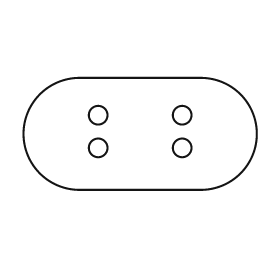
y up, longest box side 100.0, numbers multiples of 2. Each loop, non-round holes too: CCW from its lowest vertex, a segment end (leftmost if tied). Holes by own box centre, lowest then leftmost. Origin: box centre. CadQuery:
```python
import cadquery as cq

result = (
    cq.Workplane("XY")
    .moveTo(-26.0, -24.0)
    .lineTo(26.0, -24.0)
    .threePointArc((50.0, 0.0), (26.0, 24.0))
    .lineTo(-26.0, 24.0)
    .threePointArc((-50.0, 0.0), (-26.0, -24.0))
    .close()
    .moveTo(-18.0, -6.0)
    .circle(4.0)
    .moveTo(18.0, -6.0)
    .circle(4.0)
    .moveTo(-18.0, 8.0)
    .circle(4.0)
    .moveTo(18.0, 8.0)
    .circle(4.0)
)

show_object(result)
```